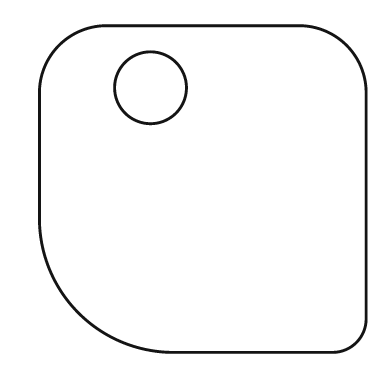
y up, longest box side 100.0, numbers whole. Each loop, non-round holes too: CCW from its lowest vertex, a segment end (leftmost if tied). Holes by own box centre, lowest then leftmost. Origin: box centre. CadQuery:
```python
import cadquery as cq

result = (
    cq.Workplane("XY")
    .moveTo(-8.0, -50.0)
    .lineTo(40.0, -50.0)
    .threePointArc((47.0, -47.0), (50.0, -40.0))
    .lineTo(50.0, 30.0)
    .threePointArc((44.0, 44.0), (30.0, 50.0))
    .lineTo(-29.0, 50.0)
    .threePointArc((-44.0, 44.0), (-50.0, 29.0))
    .lineTo(-50.0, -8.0)
    .threePointArc((-38.0, -38.0), (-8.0, -50.0))
    .close()
    .moveTo(-16.0, 31.0)
    .circle(11.0)
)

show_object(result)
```